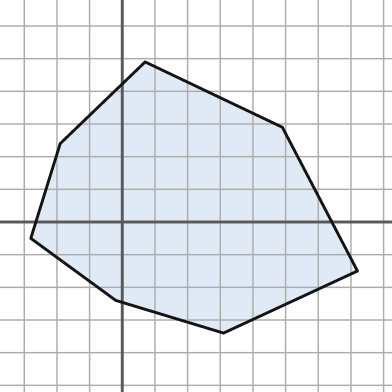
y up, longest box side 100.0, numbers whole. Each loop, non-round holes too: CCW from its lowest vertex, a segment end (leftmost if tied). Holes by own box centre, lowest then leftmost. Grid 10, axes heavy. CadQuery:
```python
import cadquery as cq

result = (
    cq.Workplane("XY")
    .moveTo(31.0, -34.0)
    .lineTo(72.0, -15.0)
    .lineTo(49.0, 29.0)
    .lineTo(7.0, 49.0)
    .lineTo(-19.0, 24.0)
    .lineTo(-28.0, -5.0)
    .lineTo(-2.0, -24.0)
    .close()
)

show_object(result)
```